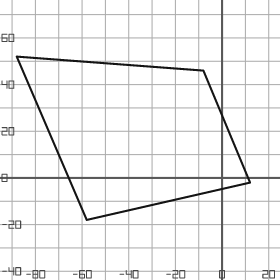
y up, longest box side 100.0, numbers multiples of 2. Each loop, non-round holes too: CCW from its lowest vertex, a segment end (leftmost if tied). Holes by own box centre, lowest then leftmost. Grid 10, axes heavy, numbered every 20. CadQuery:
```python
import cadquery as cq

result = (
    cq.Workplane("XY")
    .moveTo(-58.0, -18.0)
    .lineTo(12.0, -2.0)
    .lineTo(-8.0, 46.0)
    .lineTo(-88.0, 52.0)
    .close()
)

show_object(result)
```